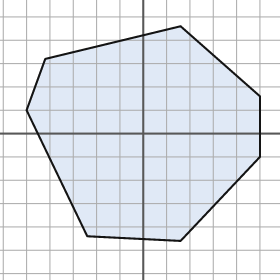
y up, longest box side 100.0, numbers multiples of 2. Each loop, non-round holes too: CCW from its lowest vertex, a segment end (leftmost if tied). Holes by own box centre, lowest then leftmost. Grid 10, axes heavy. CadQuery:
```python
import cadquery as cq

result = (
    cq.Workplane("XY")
    .moveTo(16.0, -46.0)
    .lineTo(50.0, -10.0)
    .lineTo(50.0, 16.0)
    .lineTo(16.0, 46.0)
    .lineTo(-42.0, 32.0)
    .lineTo(-50.0, 10.0)
    .lineTo(-24.0, -44.0)
    .close()
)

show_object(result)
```